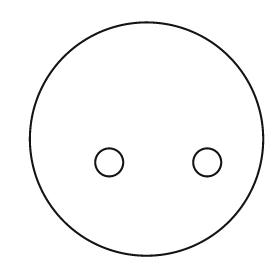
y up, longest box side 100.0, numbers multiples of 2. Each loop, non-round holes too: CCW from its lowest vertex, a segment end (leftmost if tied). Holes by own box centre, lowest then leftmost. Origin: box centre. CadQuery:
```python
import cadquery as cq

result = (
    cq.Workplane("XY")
    .moveTo(0.0, 0.0)
    .circle(50.0)
    .moveTo(-16.0, -10.0)
    .circle(6.0)
    .moveTo(26.0, -10.0)
    .circle(6.0)
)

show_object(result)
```